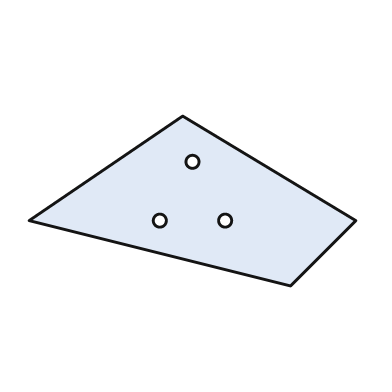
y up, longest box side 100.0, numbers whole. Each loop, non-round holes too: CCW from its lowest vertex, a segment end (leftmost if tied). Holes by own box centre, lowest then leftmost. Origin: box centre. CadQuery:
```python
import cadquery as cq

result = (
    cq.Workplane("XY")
    .moveTo(30.0, -26.0)
    .lineTo(50.0, -6.0)
    .lineTo(-3.0, 26.0)
    .lineTo(-50.0, -6.0)
    .close()
    .moveTo(-10.0, -6.0)
    .circle(2.0)
    .moveTo(10.0, -6.0)
    .circle(2.0)
    .moveTo(0.0, 12.0)
    .circle(2.0)
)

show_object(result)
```